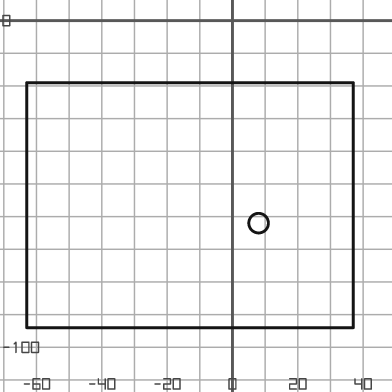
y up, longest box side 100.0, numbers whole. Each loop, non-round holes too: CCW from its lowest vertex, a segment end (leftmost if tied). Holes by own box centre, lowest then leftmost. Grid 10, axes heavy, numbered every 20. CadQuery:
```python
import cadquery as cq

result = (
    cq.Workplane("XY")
    .moveTo(-63.0, -94.0)
    .lineTo(37.0, -94.0)
    .lineTo(37.0, -19.0)
    .lineTo(-63.0, -19.0)
    .close()
    .moveTo(8.0, -62.0)
    .circle(3.0)
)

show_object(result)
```